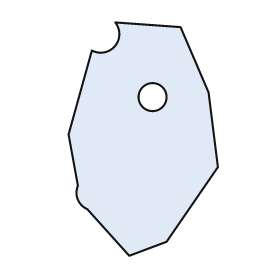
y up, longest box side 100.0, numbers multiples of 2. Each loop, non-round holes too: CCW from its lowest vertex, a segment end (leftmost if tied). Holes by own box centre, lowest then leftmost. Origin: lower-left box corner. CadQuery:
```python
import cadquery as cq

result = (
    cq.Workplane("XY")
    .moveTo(26.0, 0.0)
    .lineTo(42.0, 6.0)
    .lineTo(64.0, 38.0)
    .lineTo(60.0, 70.0)
    .lineTo(48.0, 98.0)
    .lineTo(20.0, 100.0)
    .threePointArc((20.0, 90.0), (10.0, 88.0))
    .lineTo(0.0, 52.0)
    .lineTo(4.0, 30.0)
    .threePointArc((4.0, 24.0), (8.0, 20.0))
    .close()
    .moveTo(36.0, 68.0)
    .circle(6.0)
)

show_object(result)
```